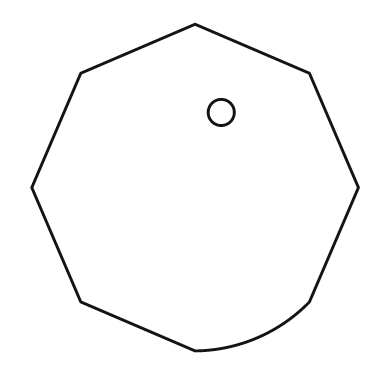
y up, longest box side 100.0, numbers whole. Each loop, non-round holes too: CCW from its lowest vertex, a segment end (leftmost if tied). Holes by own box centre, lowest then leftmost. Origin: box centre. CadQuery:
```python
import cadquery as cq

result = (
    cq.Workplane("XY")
    .moveTo(0.0, -50.0)
    .threePointArc((19.0, -46.0), (35.0, -35.0))
    .lineTo(50.0, 0.0)
    .lineTo(35.0, 35.0)
    .lineTo(0.0, 50.0)
    .lineTo(-35.0, 35.0)
    .lineTo(-50.0, 0.0)
    .lineTo(-35.0, -35.0)
    .close()
    .moveTo(8.0, 23.0)
    .circle(4.0)
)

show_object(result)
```